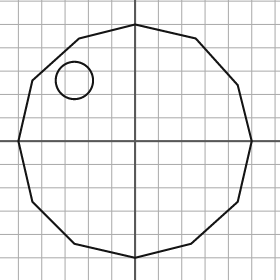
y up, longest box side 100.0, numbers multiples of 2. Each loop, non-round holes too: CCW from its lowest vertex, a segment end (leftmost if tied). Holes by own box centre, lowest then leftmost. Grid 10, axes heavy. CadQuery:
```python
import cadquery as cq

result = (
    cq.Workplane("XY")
    .moveTo(0.0, -50.0)
    .lineTo(24.0, -44.0)
    .lineTo(44.0, -26.0)
    .lineTo(50.0, 0.0)
    .lineTo(44.0, 24.0)
    .lineTo(26.0, 44.0)
    .lineTo(0.0, 50.0)
    .lineTo(-24.0, 44.0)
    .lineTo(-44.0, 26.0)
    .lineTo(-50.0, 0.0)
    .lineTo(-44.0, -26.0)
    .lineTo(-26.0, -44.0)
    .close()
    .moveTo(-26.0, 26.0)
    .circle(8.0)
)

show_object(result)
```